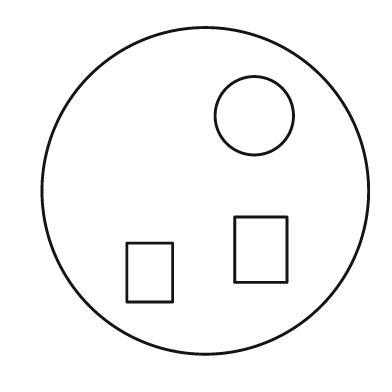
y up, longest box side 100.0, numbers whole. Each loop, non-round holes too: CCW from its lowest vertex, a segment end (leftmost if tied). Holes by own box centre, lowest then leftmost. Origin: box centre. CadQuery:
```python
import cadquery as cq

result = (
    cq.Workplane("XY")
    .moveTo(0.0, 0.0)
    .circle(50.0)
    .moveTo(-24.0, -34.0)
    .lineTo(-10.0, -34.0)
    .lineTo(-10.0, -16.0)
    .lineTo(-24.0, -16.0)
    .close()
    .moveTo(9.0, -28.0)
    .lineTo(25.0, -28.0)
    .lineTo(25.0, -8.0)
    .lineTo(9.0, -8.0)
    .close()
    .moveTo(15.0, 23.0)
    .circle(12.0)
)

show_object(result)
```